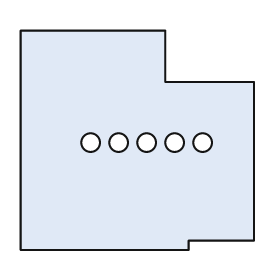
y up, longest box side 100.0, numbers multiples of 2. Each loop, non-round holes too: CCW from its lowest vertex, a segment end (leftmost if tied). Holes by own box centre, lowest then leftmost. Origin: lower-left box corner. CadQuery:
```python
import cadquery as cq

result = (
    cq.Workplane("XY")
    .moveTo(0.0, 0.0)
    .lineTo(72.0, 0.0)
    .lineTo(72.0, 4.0)
    .lineTo(100.0, 4.0)
    .lineTo(100.0, 72.0)
    .lineTo(62.0, 72.0)
    .lineTo(62.0, 94.0)
    .lineTo(0.0, 94.0)
    .close()
    .moveTo(30.0, 46.0)
    .circle(4.0)
    .moveTo(42.0, 46.0)
    .circle(4.0)
    .moveTo(54.0, 46.0)
    .circle(4.0)
    .moveTo(66.0, 46.0)
    .circle(4.0)
    .moveTo(78.0, 46.0)
    .circle(4.0)
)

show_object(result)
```